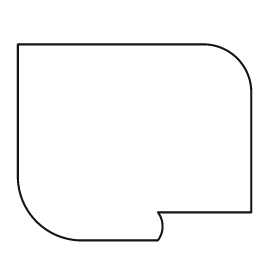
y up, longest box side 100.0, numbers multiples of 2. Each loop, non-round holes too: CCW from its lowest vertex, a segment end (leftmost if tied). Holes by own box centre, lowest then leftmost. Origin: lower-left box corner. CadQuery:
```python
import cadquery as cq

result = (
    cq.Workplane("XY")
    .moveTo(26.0, 0.0)
    .lineTo(60.0, 0.0)
    .threePointArc((62.0, 6.0), (60.0, 12.0))
    .lineTo(100.0, 12.0)
    .lineTo(100.0, 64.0)
    .threePointArc((94.0, 78.0), (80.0, 84.0))
    .lineTo(0.0, 84.0)
    .lineTo(0.0, 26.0)
    .threePointArc((8.0, 8.0), (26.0, 0.0))
    .close()
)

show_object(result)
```